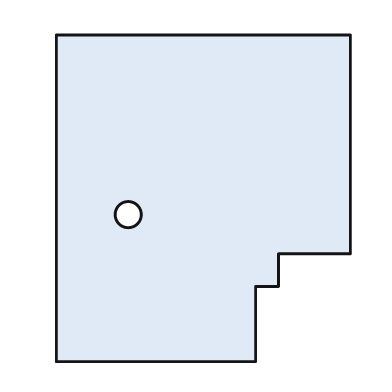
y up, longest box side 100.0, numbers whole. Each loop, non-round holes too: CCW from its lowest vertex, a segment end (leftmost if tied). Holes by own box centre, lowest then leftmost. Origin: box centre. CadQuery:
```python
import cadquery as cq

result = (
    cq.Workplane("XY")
    .moveTo(-45.0, -50.0)
    .lineTo(16.0, -50.0)
    .lineTo(16.0, -27.0)
    .lineTo(23.0, -27.0)
    .lineTo(23.0, -17.0)
    .lineTo(45.0, -17.0)
    .lineTo(45.0, 50.0)
    .lineTo(-45.0, 50.0)
    .close()
    .moveTo(-23.0, -5.0)
    .circle(4.0)
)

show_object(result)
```